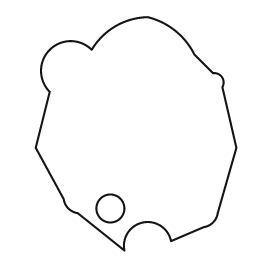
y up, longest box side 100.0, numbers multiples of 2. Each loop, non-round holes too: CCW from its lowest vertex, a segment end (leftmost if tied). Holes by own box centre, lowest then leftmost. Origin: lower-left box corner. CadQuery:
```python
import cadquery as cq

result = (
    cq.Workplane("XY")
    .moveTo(38.0, 0.0)
    .threePointArc((46.0, 12.0), (58.0, 4.0))
    .lineTo(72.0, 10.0)
    .threePointArc((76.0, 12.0), (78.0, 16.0))
    .lineTo(86.0, 44.0)
    .lineTo(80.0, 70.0)
    .threePointArc((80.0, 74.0), (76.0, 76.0))
    .lineTo(68.0, 84.0)
    .threePointArc((60.0, 94.0), (48.0, 100.0))
    .threePointArc((34.0, 96.0), (24.0, 86.0))
    .threePointArc((6.0, 86.0), (6.0, 68.0))
    .lineTo(0.0, 44.0)
    .lineTo(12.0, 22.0)
    .threePointArc((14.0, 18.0), (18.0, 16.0))
    .close()
    .moveTo(32.0, 18.0)
    .circle(6.0)
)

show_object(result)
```